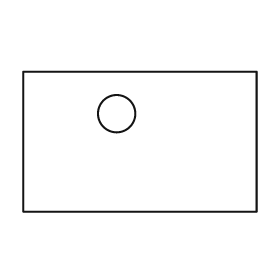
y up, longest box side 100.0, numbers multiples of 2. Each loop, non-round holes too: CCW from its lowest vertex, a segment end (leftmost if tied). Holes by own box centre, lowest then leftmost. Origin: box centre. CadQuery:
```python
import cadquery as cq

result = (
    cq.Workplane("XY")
    .moveTo(-50.0, -30.0)
    .lineTo(50.0, -30.0)
    .lineTo(50.0, 30.0)
    .lineTo(-50.0, 30.0)
    .close()
    .moveTo(-10.0, 12.0)
    .circle(8.0)
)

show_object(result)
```